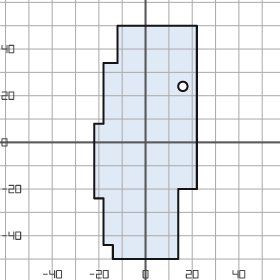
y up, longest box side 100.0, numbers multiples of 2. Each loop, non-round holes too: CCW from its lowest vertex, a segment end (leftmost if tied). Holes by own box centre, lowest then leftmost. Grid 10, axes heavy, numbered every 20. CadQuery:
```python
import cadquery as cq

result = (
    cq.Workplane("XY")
    .moveTo(-14.0, -50.0)
    .lineTo(14.0, -50.0)
    .lineTo(14.0, -20.0)
    .lineTo(22.0, -20.0)
    .lineTo(22.0, 50.0)
    .lineTo(-12.0, 50.0)
    .lineTo(-12.0, 34.0)
    .lineTo(-18.0, 34.0)
    .lineTo(-18.0, 8.0)
    .lineTo(-22.0, 8.0)
    .lineTo(-22.0, -24.0)
    .lineTo(-18.0, -24.0)
    .lineTo(-18.0, -44.0)
    .lineTo(-14.0, -44.0)
    .close()
    .moveTo(16.0, 24.0)
    .circle(2.0)
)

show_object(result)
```